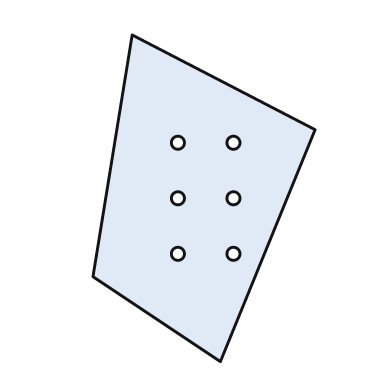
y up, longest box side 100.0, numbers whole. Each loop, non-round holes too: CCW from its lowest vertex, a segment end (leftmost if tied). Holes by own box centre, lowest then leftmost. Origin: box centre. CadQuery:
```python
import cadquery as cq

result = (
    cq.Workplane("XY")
    .moveTo(5.0, -50.0)
    .lineTo(34.0, 21.0)
    .lineTo(-22.0, 50.0)
    .lineTo(-34.0, -24.0)
    .close()
    .moveTo(-8.0, -17.0)
    .circle(2.0)
    .moveTo(9.0, -17.0)
    .circle(2.0)
    .moveTo(-8.0, 0.0)
    .circle(2.0)
    .moveTo(9.0, 0.0)
    .circle(2.0)
    .moveTo(-8.0, 17.0)
    .circle(2.0)
    .moveTo(9.0, 17.0)
    .circle(2.0)
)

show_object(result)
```